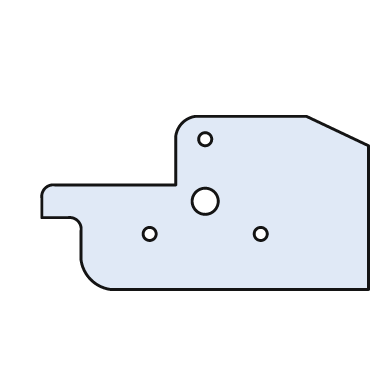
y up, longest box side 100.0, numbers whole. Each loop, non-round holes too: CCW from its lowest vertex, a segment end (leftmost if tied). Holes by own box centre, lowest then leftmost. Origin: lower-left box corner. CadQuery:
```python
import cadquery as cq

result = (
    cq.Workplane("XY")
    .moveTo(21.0, 0.0)
    .lineTo(100.0, 0.0)
    .lineTo(100.0, 44.0)
    .lineTo(81.0, 53.0)
    .lineTo(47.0, 53.0)
    .threePointArc((43.0, 51.0), (41.0, 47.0))
    .lineTo(41.0, 32.0)
    .lineTo(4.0, 32.0)
    .threePointArc((1.0, 31.0), (0.0, 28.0))
    .lineTo(0.0, 22.0)
    .lineTo(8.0, 22.0)
    .threePointArc((11.0, 21.0), (12.0, 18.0))
    .lineTo(12.0, 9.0)
    .threePointArc((15.0, 3.0), (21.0, 0.0))
    .close()
    .moveTo(33.0, 17.0)
    .circle(2.0)
    .moveTo(67.0, 17.0)
    .circle(2.0)
    .moveTo(50.0, 27.0)
    .circle(4.0)
    .moveTo(50.0, 46.0)
    .circle(2.0)
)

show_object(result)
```